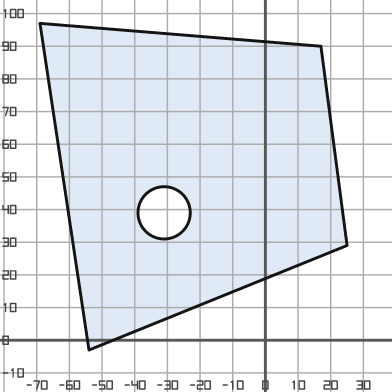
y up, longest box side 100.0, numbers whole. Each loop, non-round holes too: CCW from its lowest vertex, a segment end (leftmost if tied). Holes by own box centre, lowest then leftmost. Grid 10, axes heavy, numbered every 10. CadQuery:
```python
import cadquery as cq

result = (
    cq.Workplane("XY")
    .moveTo(-54.0, -3.0)
    .lineTo(25.0, 29.0)
    .lineTo(17.0, 90.0)
    .lineTo(-69.0, 97.0)
    .close()
    .moveTo(-31.0, 39.0)
    .circle(8.0)
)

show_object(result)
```